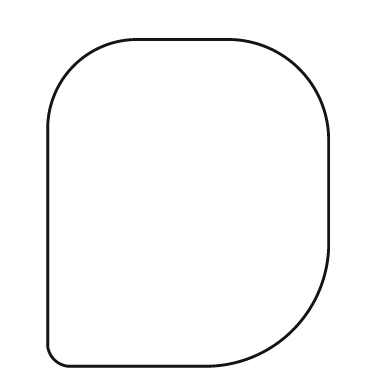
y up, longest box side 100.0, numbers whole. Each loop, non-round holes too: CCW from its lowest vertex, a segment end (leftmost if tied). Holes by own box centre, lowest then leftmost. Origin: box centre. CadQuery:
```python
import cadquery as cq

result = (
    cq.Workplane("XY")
    .moveTo(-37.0, -50.0)
    .lineTo(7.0, -50.0)
    .threePointArc((32.0, -39.0), (43.0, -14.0))
    .lineTo(43.0, 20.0)
    .threePointArc((34.0, 41.0), (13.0, 50.0))
    .lineTo(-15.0, 50.0)
    .threePointArc((-35.0, 42.0), (-43.0, 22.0))
    .lineTo(-43.0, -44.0)
    .threePointArc((-41.0, -48.0), (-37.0, -50.0))
    .close()
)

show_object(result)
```